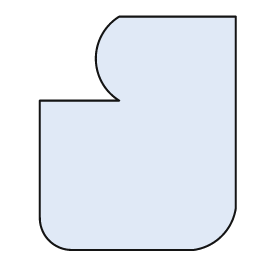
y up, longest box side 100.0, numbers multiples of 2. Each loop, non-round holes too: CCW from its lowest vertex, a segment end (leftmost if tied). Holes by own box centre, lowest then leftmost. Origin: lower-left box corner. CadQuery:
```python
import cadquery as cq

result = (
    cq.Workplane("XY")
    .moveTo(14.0, 0.0)
    .lineTo(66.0, 0.0)
    .threePointArc((78.0, 6.0), (84.0, 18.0))
    .lineTo(84.0, 100.0)
    .lineTo(34.0, 100.0)
    .threePointArc((24.0, 82.0), (34.0, 64.0))
    .lineTo(0.0, 64.0)
    .lineTo(0.0, 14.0)
    .threePointArc((4.0, 4.0), (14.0, 0.0))
    .close()
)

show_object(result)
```